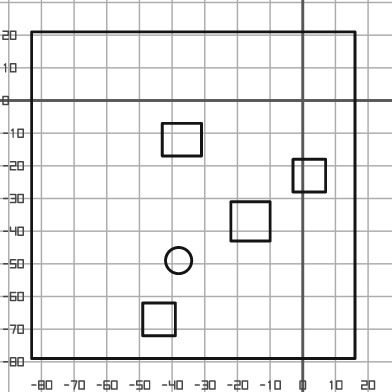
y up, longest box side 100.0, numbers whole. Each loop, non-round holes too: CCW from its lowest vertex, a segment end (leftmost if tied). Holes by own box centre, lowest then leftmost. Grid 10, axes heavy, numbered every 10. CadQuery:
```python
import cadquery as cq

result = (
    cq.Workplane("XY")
    .moveTo(-83.0, -79.0)
    .lineTo(16.0, -79.0)
    .lineTo(16.0, 21.0)
    .lineTo(-83.0, 21.0)
    .close()
    .moveTo(-49.0, -72.0)
    .lineTo(-39.0, -72.0)
    .lineTo(-39.0, -62.0)
    .lineTo(-49.0, -62.0)
    .close()
    .moveTo(-38.0, -49.0)
    .circle(4.0)
    .moveTo(-22.0, -43.0)
    .lineTo(-10.0, -43.0)
    .lineTo(-10.0, -31.0)
    .lineTo(-22.0, -31.0)
    .close()
    .moveTo(-3.0, -28.0)
    .lineTo(7.0, -28.0)
    .lineTo(7.0, -18.0)
    .lineTo(-3.0, -18.0)
    .close()
    .moveTo(-43.0, -17.0)
    .lineTo(-31.0, -17.0)
    .lineTo(-31.0, -7.0)
    .lineTo(-43.0, -7.0)
    .close()
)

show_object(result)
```